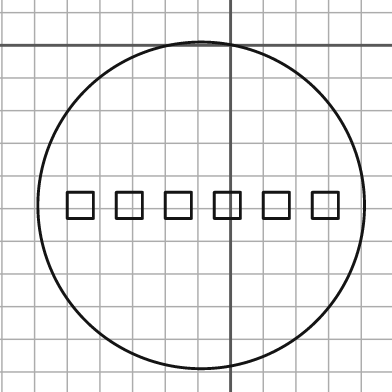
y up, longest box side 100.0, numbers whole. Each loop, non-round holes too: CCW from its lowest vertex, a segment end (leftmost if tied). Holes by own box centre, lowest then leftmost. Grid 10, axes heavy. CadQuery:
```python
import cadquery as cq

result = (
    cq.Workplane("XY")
    .moveTo(-9.0, -49.0)
    .circle(50.0)
    .moveTo(-50.0, -53.0)
    .lineTo(-42.0, -53.0)
    .lineTo(-42.0, -45.0)
    .lineTo(-50.0, -45.0)
    .close()
    .moveTo(-35.0, -53.0)
    .lineTo(-27.0, -53.0)
    .lineTo(-27.0, -45.0)
    .lineTo(-35.0, -45.0)
    .close()
    .moveTo(-20.0, -53.0)
    .lineTo(-12.0, -53.0)
    .lineTo(-12.0, -45.0)
    .lineTo(-20.0, -45.0)
    .close()
    .moveTo(-5.0, -53.0)
    .lineTo(3.0, -53.0)
    .lineTo(3.0, -45.0)
    .lineTo(-5.0, -45.0)
    .close()
    .moveTo(10.0, -53.0)
    .lineTo(18.0, -53.0)
    .lineTo(18.0, -45.0)
    .lineTo(10.0, -45.0)
    .close()
    .moveTo(25.0, -53.0)
    .lineTo(33.0, -53.0)
    .lineTo(33.0, -45.0)
    .lineTo(25.0, -45.0)
    .close()
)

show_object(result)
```